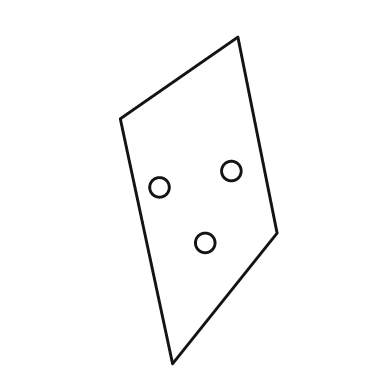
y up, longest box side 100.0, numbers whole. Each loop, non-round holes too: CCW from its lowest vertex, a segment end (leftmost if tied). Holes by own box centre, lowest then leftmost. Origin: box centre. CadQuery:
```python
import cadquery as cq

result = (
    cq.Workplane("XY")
    .moveTo(-8.0, -50.0)
    .lineTo(24.0, -10.0)
    .lineTo(12.0, 50.0)
    .lineTo(-24.0, 25.0)
    .close()
    .moveTo(2.0, -13.0)
    .circle(3.0)
    .moveTo(-12.0, 4.0)
    .circle(3.0)
    .moveTo(10.0, 9.0)
    .circle(3.0)
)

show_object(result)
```